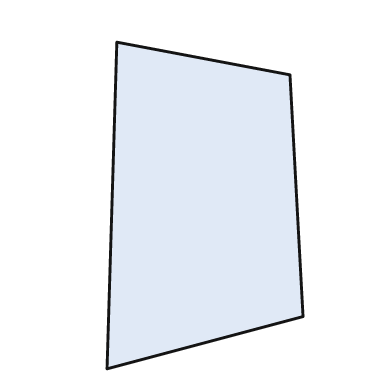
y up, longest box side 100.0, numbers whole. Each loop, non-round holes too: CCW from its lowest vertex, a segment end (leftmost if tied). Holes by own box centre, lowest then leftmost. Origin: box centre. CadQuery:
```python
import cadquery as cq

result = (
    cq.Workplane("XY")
    .moveTo(-30.0, -50.0)
    .lineTo(30.0, -34.0)
    .lineTo(26.0, 40.0)
    .lineTo(-27.0, 50.0)
    .close()
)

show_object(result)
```